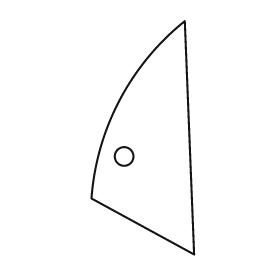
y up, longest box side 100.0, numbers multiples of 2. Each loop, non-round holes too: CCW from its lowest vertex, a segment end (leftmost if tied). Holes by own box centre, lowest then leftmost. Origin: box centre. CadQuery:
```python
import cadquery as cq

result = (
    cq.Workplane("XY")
    .moveTo(22.0, -50.0)
    .lineTo(18.0, 50.0)
    .threePointArc((-10.0, 16.0), (-22.0, -26.0))
    .close()
    .moveTo(-8.0, -8.0)
    .circle(4.0)
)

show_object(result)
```